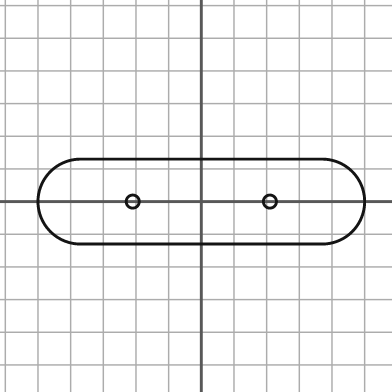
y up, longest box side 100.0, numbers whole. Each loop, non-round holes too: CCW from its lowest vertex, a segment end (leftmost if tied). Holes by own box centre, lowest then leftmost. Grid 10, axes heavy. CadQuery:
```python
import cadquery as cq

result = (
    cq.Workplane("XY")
    .moveTo(-37.0, -13.0)
    .lineTo(37.0, -13.0)
    .threePointArc((50.0, 0.0), (37.0, 13.0))
    .lineTo(-37.0, 13.0)
    .threePointArc((-50.0, 0.0), (-37.0, -13.0))
    .close()
    .moveTo(-21.0, 0.0)
    .circle(2.0)
    .moveTo(21.0, 0.0)
    .circle(2.0)
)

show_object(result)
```